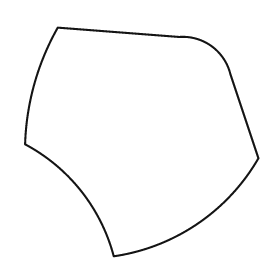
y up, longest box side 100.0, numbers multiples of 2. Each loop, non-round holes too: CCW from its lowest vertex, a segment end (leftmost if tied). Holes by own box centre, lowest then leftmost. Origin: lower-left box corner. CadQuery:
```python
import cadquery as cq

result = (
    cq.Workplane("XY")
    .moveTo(38.0, 0.0)
    .threePointArc((74.0, 14.0), (100.0, 42.0))
    .lineTo(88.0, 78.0)
    .threePointArc((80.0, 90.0), (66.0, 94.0))
    .lineTo(14.0, 98.0)
    .threePointArc((4.0, 74.0), (0.0, 48.0))
    .threePointArc((24.0, 28.0), (38.0, 0.0))
    .close()
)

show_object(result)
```